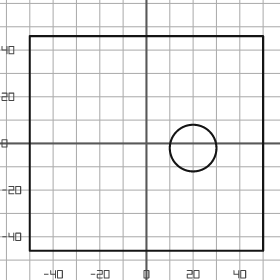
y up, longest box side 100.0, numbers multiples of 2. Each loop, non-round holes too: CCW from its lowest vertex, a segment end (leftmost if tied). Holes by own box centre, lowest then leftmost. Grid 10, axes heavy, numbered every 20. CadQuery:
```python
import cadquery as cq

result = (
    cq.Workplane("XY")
    .moveTo(-50.0, -46.0)
    .lineTo(50.0, -46.0)
    .lineTo(50.0, 46.0)
    .lineTo(-50.0, 46.0)
    .close()
    .moveTo(20.0, -2.0)
    .circle(10.0)
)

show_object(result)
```